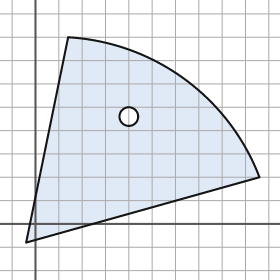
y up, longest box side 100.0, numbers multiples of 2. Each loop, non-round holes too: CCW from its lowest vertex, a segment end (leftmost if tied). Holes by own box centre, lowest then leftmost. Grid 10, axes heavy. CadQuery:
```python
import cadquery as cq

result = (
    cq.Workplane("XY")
    .moveTo(-4.0, -8.0)
    .lineTo(96.0, 20.0)
    .threePointArc((64.0, 62.0), (14.0, 80.0))
    .close()
    .moveTo(40.0, 46.0)
    .circle(4.0)
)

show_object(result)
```